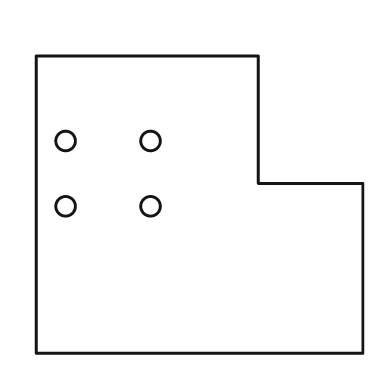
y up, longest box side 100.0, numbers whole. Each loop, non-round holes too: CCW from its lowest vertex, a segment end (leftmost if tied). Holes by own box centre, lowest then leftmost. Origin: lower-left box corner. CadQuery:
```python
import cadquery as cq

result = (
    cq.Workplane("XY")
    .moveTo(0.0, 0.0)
    .lineTo(100.0, 0.0)
    .lineTo(100.0, 52.0)
    .lineTo(68.0, 52.0)
    .lineTo(68.0, 91.0)
    .lineTo(0.0, 91.0)
    .close()
    .moveTo(9.0, 45.0)
    .circle(3.0)
    .moveTo(35.0, 45.0)
    .circle(3.0)
    .moveTo(9.0, 65.0)
    .circle(3.0)
    .moveTo(35.0, 65.0)
    .circle(3.0)
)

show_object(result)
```